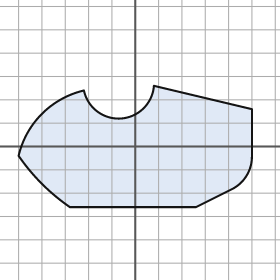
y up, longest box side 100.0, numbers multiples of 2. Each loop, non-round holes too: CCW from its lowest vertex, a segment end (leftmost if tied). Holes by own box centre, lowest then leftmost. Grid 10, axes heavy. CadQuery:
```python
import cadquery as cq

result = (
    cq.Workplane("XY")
    .moveTo(-28.0, -26.0)
    .lineTo(26.0, -26.0)
    .lineTo(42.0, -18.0)
    .threePointArc((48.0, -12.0), (50.0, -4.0))
    .lineTo(50.0, 16.0)
    .lineTo(8.0, 26.0)
    .threePointArc((-6.0, 12.0), (-22.0, 24.0))
    .threePointArc((-40.0, 14.0), (-50.0, -4.0))
    .threePointArc((-40.0, -16.0), (-28.0, -26.0))
    .close()
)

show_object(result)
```